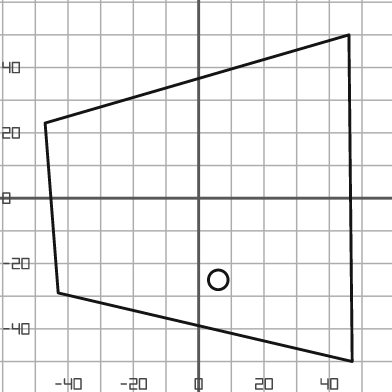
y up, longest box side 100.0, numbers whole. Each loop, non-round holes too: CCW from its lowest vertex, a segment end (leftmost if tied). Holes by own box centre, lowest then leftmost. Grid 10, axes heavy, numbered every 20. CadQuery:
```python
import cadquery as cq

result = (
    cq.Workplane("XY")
    .moveTo(47.0, -50.0)
    .lineTo(46.0, 50.0)
    .lineTo(-47.0, 23.0)
    .lineTo(-43.0, -29.0)
    .close()
    .moveTo(6.0, -25.0)
    .circle(3.0)
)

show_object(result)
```